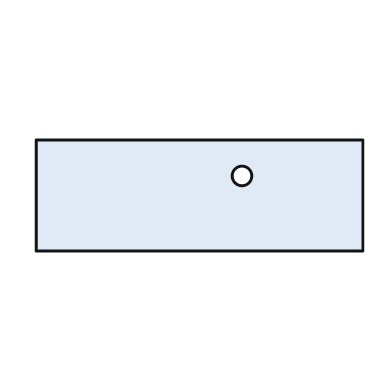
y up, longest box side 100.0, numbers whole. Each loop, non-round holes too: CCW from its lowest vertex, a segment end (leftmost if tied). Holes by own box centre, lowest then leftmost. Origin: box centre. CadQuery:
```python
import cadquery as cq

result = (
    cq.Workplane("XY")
    .moveTo(-50.0, -17.0)
    .lineTo(50.0, -17.0)
    .lineTo(50.0, 17.0)
    .lineTo(-50.0, 17.0)
    .close()
    .moveTo(13.0, 6.0)
    .circle(3.0)
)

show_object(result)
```